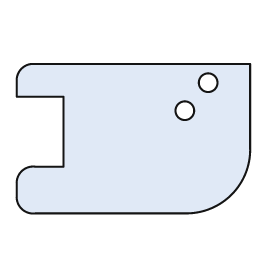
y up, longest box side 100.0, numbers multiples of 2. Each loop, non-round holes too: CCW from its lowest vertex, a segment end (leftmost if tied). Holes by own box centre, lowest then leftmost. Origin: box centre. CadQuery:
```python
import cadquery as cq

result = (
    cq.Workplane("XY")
    .moveTo(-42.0, -32.0)
    .lineTo(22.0, -32.0)
    .threePointArc((42.0, -24.0), (50.0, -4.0))
    .lineTo(50.0, 32.0)
    .lineTo(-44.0, 32.0)
    .threePointArc((-48.0, 30.0), (-50.0, 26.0))
    .lineTo(-50.0, 18.0)
    .lineTo(-30.0, 18.0)
    .lineTo(-30.0, -12.0)
    .lineTo(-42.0, -12.0)
    .threePointArc((-48.0, -14.0), (-50.0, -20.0))
    .lineTo(-50.0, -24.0)
    .threePointArc((-48.0, -30.0), (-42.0, -32.0))
    .close()
    .moveTo(22.0, 12.0)
    .circle(4.0)
    .moveTo(32.0, 24.0)
    .circle(4.0)
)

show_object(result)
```